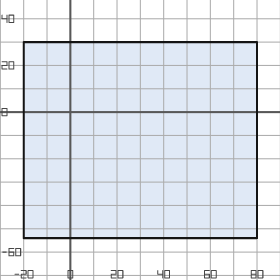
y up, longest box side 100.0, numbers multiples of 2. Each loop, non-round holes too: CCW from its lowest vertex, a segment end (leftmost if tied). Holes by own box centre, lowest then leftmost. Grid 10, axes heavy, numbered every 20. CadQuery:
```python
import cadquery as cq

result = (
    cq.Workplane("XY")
    .moveTo(-20.0, -54.0)
    .lineTo(80.0, -54.0)
    .lineTo(80.0, 30.0)
    .lineTo(-20.0, 30.0)
    .close()
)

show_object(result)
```